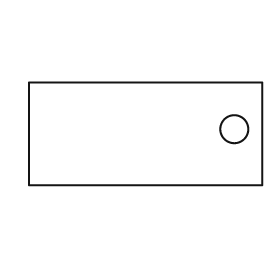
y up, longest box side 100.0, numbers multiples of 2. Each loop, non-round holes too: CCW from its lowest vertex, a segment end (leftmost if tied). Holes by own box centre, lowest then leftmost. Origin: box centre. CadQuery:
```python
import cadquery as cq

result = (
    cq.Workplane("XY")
    .moveTo(-50.0, -22.0)
    .lineTo(50.0, -22.0)
    .lineTo(50.0, 22.0)
    .lineTo(-50.0, 22.0)
    .close()
    .moveTo(38.0, 2.0)
    .circle(6.0)
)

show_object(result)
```